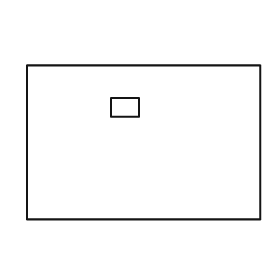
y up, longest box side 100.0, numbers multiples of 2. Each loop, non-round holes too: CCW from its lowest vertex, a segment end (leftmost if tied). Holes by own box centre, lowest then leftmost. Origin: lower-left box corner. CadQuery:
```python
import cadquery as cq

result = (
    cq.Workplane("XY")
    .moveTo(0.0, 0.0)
    .lineTo(100.0, 0.0)
    .lineTo(100.0, 66.0)
    .lineTo(0.0, 66.0)
    .close()
    .moveTo(36.0, 44.0)
    .lineTo(48.0, 44.0)
    .lineTo(48.0, 52.0)
    .lineTo(36.0, 52.0)
    .close()
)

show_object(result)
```